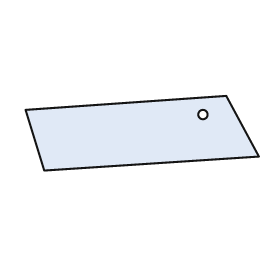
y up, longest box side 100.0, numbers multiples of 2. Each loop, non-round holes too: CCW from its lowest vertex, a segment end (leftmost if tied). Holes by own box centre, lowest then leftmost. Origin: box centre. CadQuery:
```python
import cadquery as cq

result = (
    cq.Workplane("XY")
    .moveTo(-42.0, -16.0)
    .lineTo(50.0, -10.0)
    .lineTo(36.0, 16.0)
    .lineTo(-50.0, 10.0)
    .close()
    .moveTo(26.0, 8.0)
    .circle(2.0)
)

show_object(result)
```